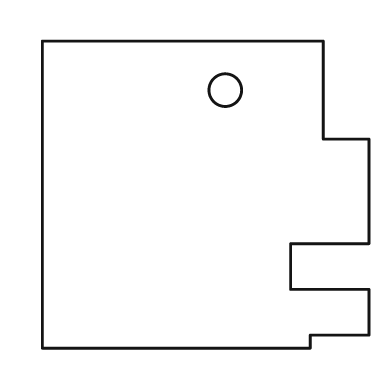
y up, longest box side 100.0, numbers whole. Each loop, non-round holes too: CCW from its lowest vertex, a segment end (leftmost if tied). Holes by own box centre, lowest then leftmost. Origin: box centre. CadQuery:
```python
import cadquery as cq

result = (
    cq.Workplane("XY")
    .moveTo(-50.0, -47.0)
    .lineTo(32.0, -47.0)
    .lineTo(32.0, -43.0)
    .lineTo(50.0, -43.0)
    .lineTo(50.0, -29.0)
    .lineTo(26.0, -29.0)
    .lineTo(26.0, -15.0)
    .lineTo(50.0, -15.0)
    .lineTo(50.0, 17.0)
    .lineTo(36.0, 17.0)
    .lineTo(36.0, 47.0)
    .lineTo(-50.0, 47.0)
    .close()
    .moveTo(6.0, 32.0)
    .circle(5.0)
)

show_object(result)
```